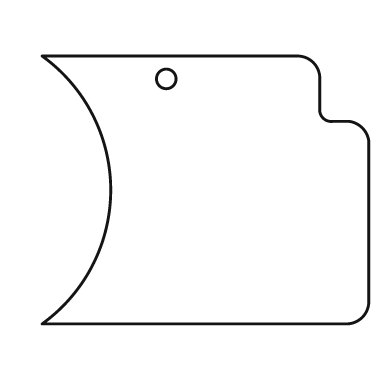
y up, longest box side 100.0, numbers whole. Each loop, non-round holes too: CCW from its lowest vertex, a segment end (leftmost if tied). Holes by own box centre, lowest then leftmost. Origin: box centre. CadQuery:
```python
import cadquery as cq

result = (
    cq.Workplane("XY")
    .moveTo(-50.0, -41.0)
    .lineTo(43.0, -41.0)
    .threePointArc((48.0, -39.0), (50.0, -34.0))
    .lineTo(50.0, 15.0)
    .threePointArc((48.0, 19.0), (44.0, 21.0))
    .lineTo(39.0, 21.0)
    .threePointArc((36.0, 22.0), (35.0, 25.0))
    .lineTo(35.0, 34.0)
    .threePointArc((33.0, 39.0), (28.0, 41.0))
    .lineTo(-50.0, 41.0)
    .threePointArc((-29.0, 0.0), (-50.0, -41.0))
    .close()
    .moveTo(-12.0, 34.0)
    .circle(3.0)
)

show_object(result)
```